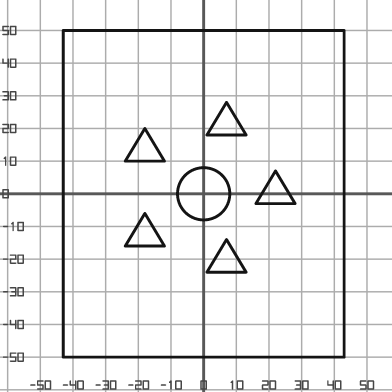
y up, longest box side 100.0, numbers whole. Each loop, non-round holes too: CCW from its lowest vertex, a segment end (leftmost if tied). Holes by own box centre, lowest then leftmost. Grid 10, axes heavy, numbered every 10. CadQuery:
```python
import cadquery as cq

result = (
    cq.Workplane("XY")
    .moveTo(-43.0, -50.0)
    .lineTo(43.0, -50.0)
    .lineTo(43.0, 50.0)
    .lineTo(-43.0, 50.0)
    .close()
    .moveTo(1.0, -24.0)
    .lineTo(13.0, -24.0)
    .lineTo(7.0, -14.0)
    .close()
    .moveTo(-24.0, -16.0)
    .lineTo(-12.0, -16.0)
    .lineTo(-18.0, -6.0)
    .close()
    .moveTo(0.0, 0.0)
    .circle(8.0)
    .moveTo(16.0, -3.0)
    .lineTo(28.0, -3.0)
    .lineTo(22.0, 7.0)
    .close()
    .moveTo(-24.0, 10.0)
    .lineTo(-12.0, 10.0)
    .lineTo(-18.0, 20.0)
    .close()
    .moveTo(1.0, 18.0)
    .lineTo(13.0, 18.0)
    .lineTo(7.0, 28.0)
    .close()
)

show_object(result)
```